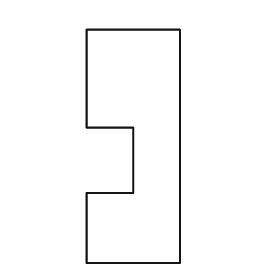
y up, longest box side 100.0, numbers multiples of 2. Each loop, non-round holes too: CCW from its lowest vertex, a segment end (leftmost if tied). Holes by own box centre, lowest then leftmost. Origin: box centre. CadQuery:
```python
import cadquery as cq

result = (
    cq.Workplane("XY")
    .moveTo(-20.0, -50.0)
    .lineTo(20.0, -50.0)
    .lineTo(20.0, 50.0)
    .lineTo(-20.0, 50.0)
    .lineTo(-20.0, 8.0)
    .lineTo(0.0, 8.0)
    .lineTo(0.0, -20.0)
    .lineTo(-20.0, -20.0)
    .close()
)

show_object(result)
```